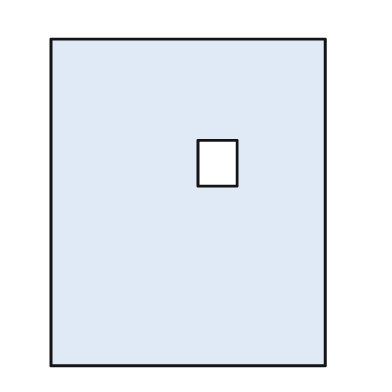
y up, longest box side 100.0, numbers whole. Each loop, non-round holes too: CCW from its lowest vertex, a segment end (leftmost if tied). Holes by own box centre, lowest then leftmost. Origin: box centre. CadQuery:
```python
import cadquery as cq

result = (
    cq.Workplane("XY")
    .moveTo(-42.0, -50.0)
    .lineTo(42.0, -50.0)
    .lineTo(42.0, 50.0)
    .lineTo(-42.0, 50.0)
    .close()
    .moveTo(3.0, 5.0)
    .lineTo(15.0, 5.0)
    .lineTo(15.0, 19.0)
    .lineTo(3.0, 19.0)
    .close()
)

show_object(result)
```